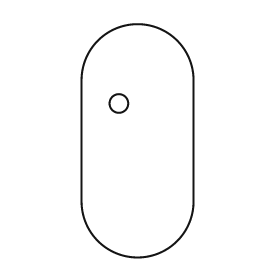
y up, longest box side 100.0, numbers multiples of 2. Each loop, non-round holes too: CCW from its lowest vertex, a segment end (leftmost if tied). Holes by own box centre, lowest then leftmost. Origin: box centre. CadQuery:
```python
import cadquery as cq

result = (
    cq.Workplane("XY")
    .moveTo(-24.0, -26.0)
    .threePointArc((0.0, -50.0), (24.0, -26.0))
    .lineTo(24.0, 26.0)
    .threePointArc((0.0, 50.0), (-24.0, 26.0))
    .close()
    .moveTo(-8.0, 16.0)
    .circle(4.0)
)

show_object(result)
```